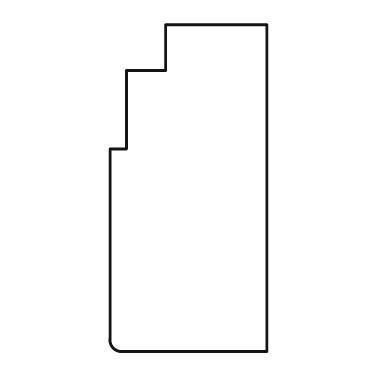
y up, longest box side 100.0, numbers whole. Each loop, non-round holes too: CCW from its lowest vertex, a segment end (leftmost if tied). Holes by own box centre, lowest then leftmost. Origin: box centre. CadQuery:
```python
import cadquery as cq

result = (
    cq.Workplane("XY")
    .moveTo(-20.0, -50.0)
    .lineTo(24.0, -50.0)
    .lineTo(24.0, 50.0)
    .lineTo(-7.0, 50.0)
    .lineTo(-7.0, 36.0)
    .lineTo(-19.0, 36.0)
    .lineTo(-19.0, 12.0)
    .lineTo(-24.0, 12.0)
    .lineTo(-24.0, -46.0)
    .threePointArc((-23.0, -49.0), (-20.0, -50.0))
    .close()
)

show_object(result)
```